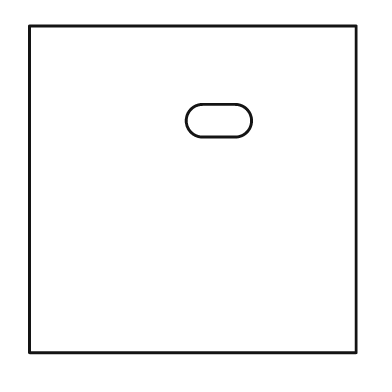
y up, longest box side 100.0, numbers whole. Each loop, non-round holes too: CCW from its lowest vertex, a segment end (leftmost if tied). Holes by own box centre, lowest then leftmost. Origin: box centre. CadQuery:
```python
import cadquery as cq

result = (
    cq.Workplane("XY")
    .moveTo(-50.0, -50.0)
    .lineTo(50.0, -50.0)
    .lineTo(50.0, 50.0)
    .lineTo(-50.0, 50.0)
    .close()
    .moveTo(3.0, 16.0)
    .lineTo(13.0, 16.0)
    .threePointArc((18.0, 21.0), (13.0, 26.0))
    .lineTo(3.0, 26.0)
    .threePointArc((-2.0, 21.0), (3.0, 16.0))
    .close()
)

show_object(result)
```